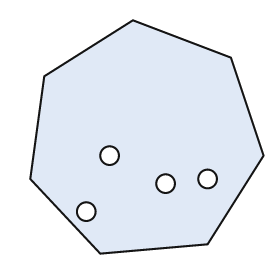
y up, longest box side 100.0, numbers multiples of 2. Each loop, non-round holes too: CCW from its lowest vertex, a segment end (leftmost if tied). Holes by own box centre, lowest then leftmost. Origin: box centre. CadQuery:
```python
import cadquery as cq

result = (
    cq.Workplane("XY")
    .moveTo(-20.0, -50.0)
    .lineTo(26.0, -46.0)
    .lineTo(50.0, -8.0)
    .lineTo(36.0, 34.0)
    .lineTo(-6.0, 50.0)
    .lineTo(-44.0, 26.0)
    .lineTo(-50.0, -18.0)
    .close()
    .moveTo(-26.0, -32.0)
    .circle(4.0)
    .moveTo(8.0, -20.0)
    .circle(4.0)
    .moveTo(26.0, -18.0)
    .circle(4.0)
    .moveTo(-16.0, -8.0)
    .circle(4.0)
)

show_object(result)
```